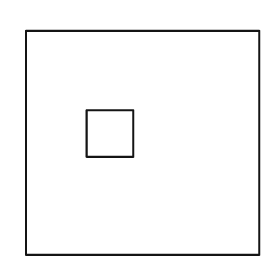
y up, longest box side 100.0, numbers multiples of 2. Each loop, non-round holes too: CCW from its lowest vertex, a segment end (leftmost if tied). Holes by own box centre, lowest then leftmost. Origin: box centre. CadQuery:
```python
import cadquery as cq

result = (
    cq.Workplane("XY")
    .moveTo(-50.0, -48.0)
    .lineTo(50.0, -48.0)
    .lineTo(50.0, 48.0)
    .lineTo(-50.0, 48.0)
    .close()
    .moveTo(-24.0, -6.0)
    .lineTo(-4.0, -6.0)
    .lineTo(-4.0, 14.0)
    .lineTo(-24.0, 14.0)
    .close()
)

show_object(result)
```